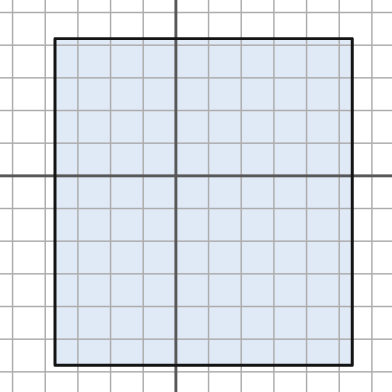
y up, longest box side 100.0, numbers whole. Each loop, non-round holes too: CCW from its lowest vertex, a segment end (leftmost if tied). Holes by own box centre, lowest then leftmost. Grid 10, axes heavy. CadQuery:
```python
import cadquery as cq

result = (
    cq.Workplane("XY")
    .moveTo(-37.0, -58.0)
    .lineTo(54.0, -58.0)
    .lineTo(54.0, 42.0)
    .lineTo(-37.0, 42.0)
    .close()
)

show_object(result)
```